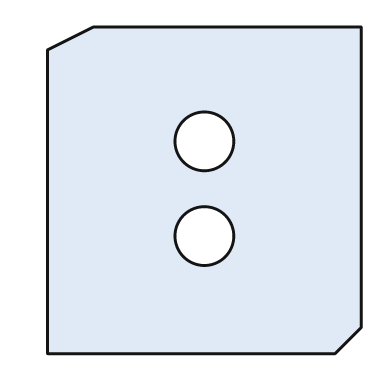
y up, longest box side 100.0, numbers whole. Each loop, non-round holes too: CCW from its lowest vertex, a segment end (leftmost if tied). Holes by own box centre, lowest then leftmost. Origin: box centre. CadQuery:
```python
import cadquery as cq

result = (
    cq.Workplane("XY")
    .moveTo(-48.0, -50.0)
    .lineTo(40.0, -50.0)
    .lineTo(48.0, -42.0)
    .lineTo(48.0, 50.0)
    .lineTo(-34.0, 50.0)
    .lineTo(-48.0, 43.0)
    .close()
    .moveTo(0.0, -14.0)
    .circle(9.0)
    .moveTo(0.0, 15.0)
    .circle(9.0)
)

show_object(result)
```